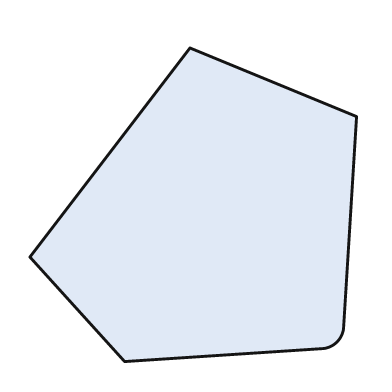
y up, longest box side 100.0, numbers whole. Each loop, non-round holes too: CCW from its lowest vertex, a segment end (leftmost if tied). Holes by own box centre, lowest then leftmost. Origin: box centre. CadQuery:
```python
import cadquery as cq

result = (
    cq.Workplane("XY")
    .moveTo(-21.0, -48.0)
    .lineTo(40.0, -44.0)
    .threePointArc((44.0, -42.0), (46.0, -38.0))
    .lineTo(50.0, 27.0)
    .lineTo(-1.0, 48.0)
    .lineTo(-50.0, -16.0)
    .close()
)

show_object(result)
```